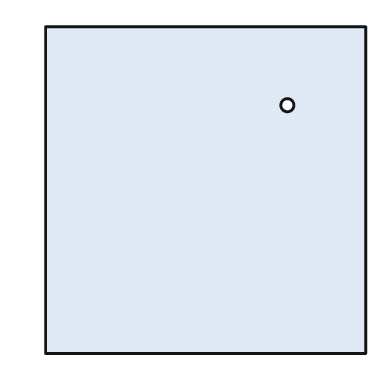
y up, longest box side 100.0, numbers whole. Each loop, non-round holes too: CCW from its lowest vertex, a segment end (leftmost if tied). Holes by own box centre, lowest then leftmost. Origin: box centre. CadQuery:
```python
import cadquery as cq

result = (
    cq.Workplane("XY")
    .moveTo(-49.0, -50.0)
    .lineTo(49.0, -50.0)
    .lineTo(49.0, 50.0)
    .lineTo(-49.0, 50.0)
    .close()
    .moveTo(25.0, 26.0)
    .circle(2.0)
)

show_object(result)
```